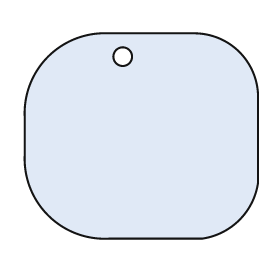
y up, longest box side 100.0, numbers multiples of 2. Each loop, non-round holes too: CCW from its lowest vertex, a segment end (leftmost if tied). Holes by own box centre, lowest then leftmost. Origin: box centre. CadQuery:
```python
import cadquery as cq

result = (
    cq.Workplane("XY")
    .moveTo(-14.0, -44.0)
    .lineTo(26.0, -44.0)
    .threePointArc((42.0, -36.0), (50.0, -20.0))
    .lineTo(50.0, 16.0)
    .threePointArc((42.0, 36.0), (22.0, 44.0))
    .lineTo(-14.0, 44.0)
    .threePointArc((-40.0, 34.0), (-50.0, 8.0))
    .lineTo(-50.0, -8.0)
    .threePointArc((-40.0, -34.0), (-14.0, -44.0))
    .close()
    .moveTo(-8.0, 34.0)
    .circle(4.0)
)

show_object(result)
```